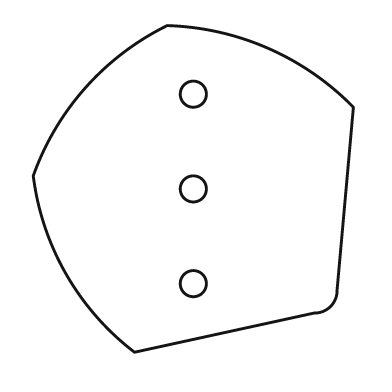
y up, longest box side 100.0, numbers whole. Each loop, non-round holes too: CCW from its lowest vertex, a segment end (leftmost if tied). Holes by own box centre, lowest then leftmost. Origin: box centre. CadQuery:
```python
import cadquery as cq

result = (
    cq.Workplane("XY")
    .moveTo(-18.0, -50.0)
    .lineTo(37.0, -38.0)
    .threePointArc((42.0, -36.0), (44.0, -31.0))
    .lineTo(49.0, 25.0)
    .threePointArc((23.0, 43.0), (-8.0, 50.0))
    .threePointArc((-33.0, 31.0), (-49.0, 4.0))
    .threePointArc((-39.0, -26.0), (-18.0, -50.0))
    .close()
    .moveTo(0.0, -29.0)
    .circle(4.0)
    .moveTo(0.0, 0.0)
    .circle(4.0)
    .moveTo(0.0, 29.0)
    .circle(4.0)
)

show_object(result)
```